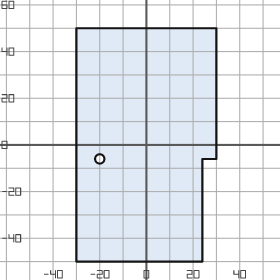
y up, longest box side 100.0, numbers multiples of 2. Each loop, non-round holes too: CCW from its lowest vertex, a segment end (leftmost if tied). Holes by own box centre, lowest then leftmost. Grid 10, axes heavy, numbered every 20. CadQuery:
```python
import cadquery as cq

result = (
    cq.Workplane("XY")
    .moveTo(-30.0, -50.0)
    .lineTo(24.0, -50.0)
    .lineTo(24.0, -6.0)
    .lineTo(30.0, -6.0)
    .lineTo(30.0, 50.0)
    .lineTo(-30.0, 50.0)
    .close()
    .moveTo(-20.0, -6.0)
    .circle(2.0)
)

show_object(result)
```